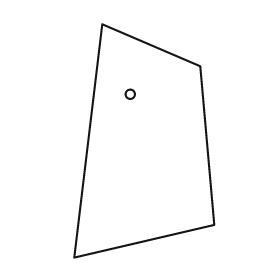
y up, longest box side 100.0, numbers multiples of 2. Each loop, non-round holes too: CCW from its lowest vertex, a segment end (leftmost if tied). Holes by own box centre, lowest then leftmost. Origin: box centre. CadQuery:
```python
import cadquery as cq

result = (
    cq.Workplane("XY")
    .moveTo(-30.0, -50.0)
    .lineTo(30.0, -36.0)
    .lineTo(24.0, 32.0)
    .lineTo(-18.0, 50.0)
    .close()
    .moveTo(-6.0, 20.0)
    .circle(2.0)
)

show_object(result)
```